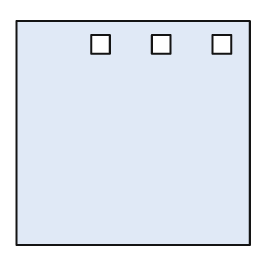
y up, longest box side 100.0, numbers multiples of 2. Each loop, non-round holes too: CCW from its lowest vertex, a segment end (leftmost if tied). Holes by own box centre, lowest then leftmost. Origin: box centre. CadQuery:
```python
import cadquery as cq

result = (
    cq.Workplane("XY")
    .moveTo(-50.0, -48.0)
    .lineTo(50.0, -48.0)
    .lineTo(50.0, 48.0)
    .lineTo(-50.0, 48.0)
    .close()
    .moveTo(-18.0, 34.0)
    .lineTo(-10.0, 34.0)
    .lineTo(-10.0, 42.0)
    .lineTo(-18.0, 42.0)
    .close()
    .moveTo(8.0, 34.0)
    .lineTo(16.0, 34.0)
    .lineTo(16.0, 42.0)
    .lineTo(8.0, 42.0)
    .close()
    .moveTo(34.0, 34.0)
    .lineTo(42.0, 34.0)
    .lineTo(42.0, 42.0)
    .lineTo(34.0, 42.0)
    .close()
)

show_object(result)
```